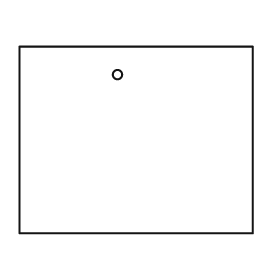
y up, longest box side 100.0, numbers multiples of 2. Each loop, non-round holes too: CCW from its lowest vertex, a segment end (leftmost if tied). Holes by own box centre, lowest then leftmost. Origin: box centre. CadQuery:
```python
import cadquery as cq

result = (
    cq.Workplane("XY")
    .moveTo(-50.0, -40.0)
    .lineTo(50.0, -40.0)
    .lineTo(50.0, 40.0)
    .lineTo(-50.0, 40.0)
    .close()
    .moveTo(-8.0, 28.0)
    .circle(2.0)
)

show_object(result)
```